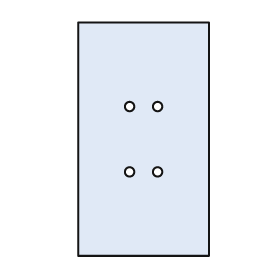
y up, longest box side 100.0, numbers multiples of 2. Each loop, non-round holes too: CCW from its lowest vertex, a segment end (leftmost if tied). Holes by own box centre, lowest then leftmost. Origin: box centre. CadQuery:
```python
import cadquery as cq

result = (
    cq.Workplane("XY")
    .moveTo(-28.0, -50.0)
    .lineTo(28.0, -50.0)
    .lineTo(28.0, 50.0)
    .lineTo(-28.0, 50.0)
    .close()
    .moveTo(-6.0, -14.0)
    .circle(2.0)
    .moveTo(6.0, -14.0)
    .circle(2.0)
    .moveTo(-6.0, 14.0)
    .circle(2.0)
    .moveTo(6.0, 14.0)
    .circle(2.0)
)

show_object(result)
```